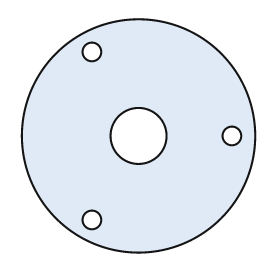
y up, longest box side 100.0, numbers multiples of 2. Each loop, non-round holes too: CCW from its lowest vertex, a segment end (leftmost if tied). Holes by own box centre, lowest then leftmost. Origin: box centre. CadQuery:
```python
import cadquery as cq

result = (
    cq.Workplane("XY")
    .moveTo(0.0, 0.0)
    .circle(50.0)
    .moveTo(-20.0, -36.0)
    .circle(4.0)
    .moveTo(0.0, 0.0)
    .circle(12.0)
    .moveTo(40.0, 0.0)
    .circle(4.0)
    .moveTo(-20.0, 36.0)
    .circle(4.0)
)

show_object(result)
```